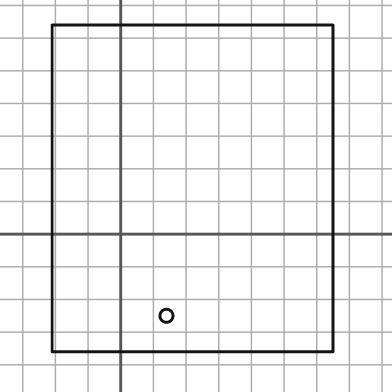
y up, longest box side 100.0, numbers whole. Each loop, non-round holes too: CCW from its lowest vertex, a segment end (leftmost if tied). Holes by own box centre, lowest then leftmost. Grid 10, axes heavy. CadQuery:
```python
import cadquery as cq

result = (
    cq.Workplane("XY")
    .moveTo(-21.0, -36.0)
    .lineTo(65.0, -36.0)
    .lineTo(65.0, 64.0)
    .lineTo(-21.0, 64.0)
    .close()
    .moveTo(14.0, -25.0)
    .circle(2.0)
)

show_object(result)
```